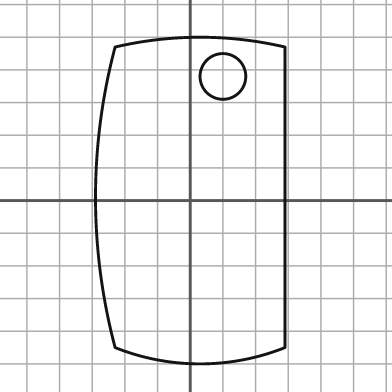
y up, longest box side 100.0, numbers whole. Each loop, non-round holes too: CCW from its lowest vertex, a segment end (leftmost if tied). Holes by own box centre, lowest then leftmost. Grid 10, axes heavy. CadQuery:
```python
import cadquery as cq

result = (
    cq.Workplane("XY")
    .moveTo(-23.0, -45.0)
    .threePointArc((3.0, -50.0), (29.0, -45.0))
    .lineTo(29.0, 47.0)
    .threePointArc((3.0, 50.0), (-23.0, 47.0))
    .threePointArc((-29.0, 1.0), (-23.0, -45.0))
    .close()
    .moveTo(10.0, 38.0)
    .circle(7.0)
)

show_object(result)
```